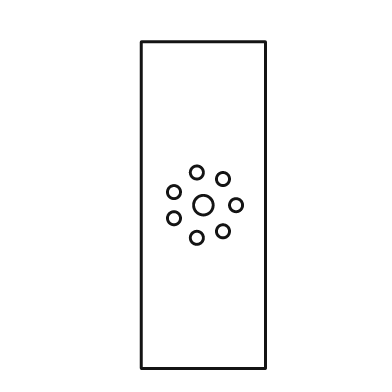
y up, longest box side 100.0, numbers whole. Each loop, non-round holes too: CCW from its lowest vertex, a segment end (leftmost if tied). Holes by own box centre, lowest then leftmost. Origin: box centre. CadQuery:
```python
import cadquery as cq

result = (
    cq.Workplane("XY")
    .moveTo(-19.0, -50.0)
    .lineTo(19.0, -50.0)
    .lineTo(19.0, 50.0)
    .lineTo(-19.0, 50.0)
    .close()
    .moveTo(-2.0, -10.0)
    .circle(2.0)
    .moveTo(6.0, -8.0)
    .circle(2.0)
    .moveTo(-9.0, -4.0)
    .circle(2.0)
    .moveTo(0.0, 0.0)
    .circle(3.0)
    .moveTo(10.0, 0.0)
    .circle(2.0)
    .moveTo(-9.0, 4.0)
    .circle(2.0)
    .moveTo(6.0, 8.0)
    .circle(2.0)
    .moveTo(-2.0, 10.0)
    .circle(2.0)
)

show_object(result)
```